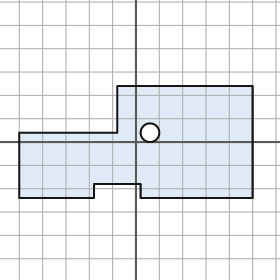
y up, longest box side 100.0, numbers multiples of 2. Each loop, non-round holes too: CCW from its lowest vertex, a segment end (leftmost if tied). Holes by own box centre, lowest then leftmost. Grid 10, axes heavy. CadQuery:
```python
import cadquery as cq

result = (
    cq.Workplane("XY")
    .moveTo(-50.0, -24.0)
    .lineTo(-18.0, -24.0)
    .lineTo(-18.0, -18.0)
    .lineTo(2.0, -18.0)
    .lineTo(2.0, -24.0)
    .lineTo(50.0, -24.0)
    .lineTo(50.0, 24.0)
    .lineTo(-8.0, 24.0)
    .lineTo(-8.0, 4.0)
    .lineTo(-50.0, 4.0)
    .close()
    .moveTo(6.0, 4.0)
    .circle(4.0)
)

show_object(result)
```